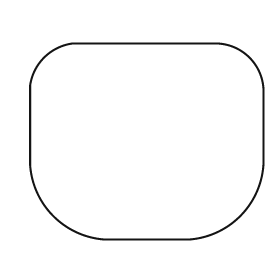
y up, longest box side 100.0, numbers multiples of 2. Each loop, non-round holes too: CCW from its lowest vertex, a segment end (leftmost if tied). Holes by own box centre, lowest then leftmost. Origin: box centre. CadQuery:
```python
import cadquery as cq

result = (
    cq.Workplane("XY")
    .moveTo(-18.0, -42.0)
    .lineTo(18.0, -42.0)
    .threePointArc((40.0, -32.0), (50.0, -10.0))
    .lineTo(50.0, 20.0)
    .threePointArc((44.0, 36.0), (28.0, 42.0))
    .lineTo(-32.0, 42.0)
    .threePointArc((-44.0, 36.0), (-50.0, 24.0))
    .lineTo(-50.0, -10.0)
    .threePointArc((-40.0, -32.0), (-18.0, -42.0))
    .close()
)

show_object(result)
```